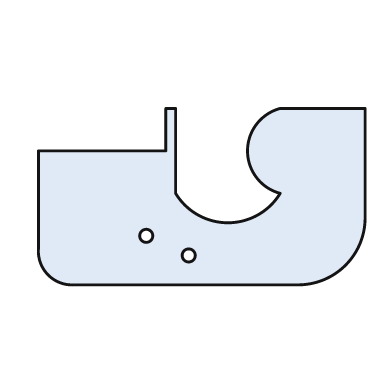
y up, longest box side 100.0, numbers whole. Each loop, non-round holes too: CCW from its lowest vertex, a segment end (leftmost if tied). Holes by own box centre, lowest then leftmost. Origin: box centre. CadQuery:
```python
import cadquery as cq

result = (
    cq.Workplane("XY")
    .moveTo(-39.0, -27.0)
    .lineTo(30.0, -27.0)
    .threePointArc((44.0, -21.0), (50.0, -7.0))
    .lineTo(50.0, 27.0)
    .lineTo(24.0, 27.0)
    .threePointArc((14.0, 14.0), (24.0, 1.0))
    .threePointArc((8.0, -8.0), (-8.0, 1.0))
    .lineTo(-8.0, 27.0)
    .lineTo(-11.0, 27.0)
    .lineTo(-11.0, 14.0)
    .lineTo(-50.0, 14.0)
    .lineTo(-50.0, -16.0)
    .threePointArc((-47.0, -24.0), (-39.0, -27.0))
    .close()
    .moveTo(-4.0, -18.0)
    .circle(2.0)
    .moveTo(-17.0, -12.0)
    .circle(2.0)
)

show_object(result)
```